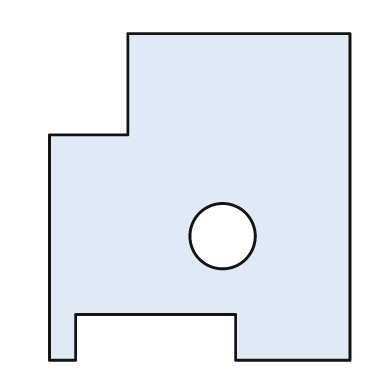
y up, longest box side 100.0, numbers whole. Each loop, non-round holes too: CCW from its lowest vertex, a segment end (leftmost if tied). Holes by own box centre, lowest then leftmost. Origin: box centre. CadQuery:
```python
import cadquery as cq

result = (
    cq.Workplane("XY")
    .moveTo(-46.0, -50.0)
    .lineTo(-38.0, -50.0)
    .lineTo(-38.0, -36.0)
    .lineTo(11.0, -36.0)
    .lineTo(11.0, -50.0)
    .lineTo(46.0, -50.0)
    .lineTo(46.0, 50.0)
    .lineTo(-22.0, 50.0)
    .lineTo(-22.0, 19.0)
    .lineTo(-46.0, 19.0)
    .close()
    .moveTo(7.0, -12.0)
    .circle(10.0)
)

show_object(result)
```